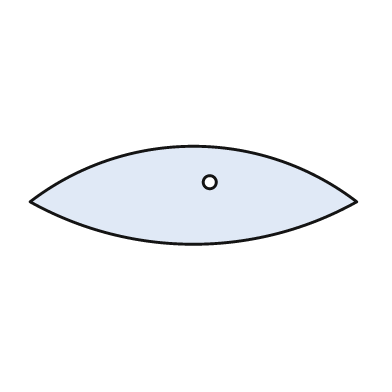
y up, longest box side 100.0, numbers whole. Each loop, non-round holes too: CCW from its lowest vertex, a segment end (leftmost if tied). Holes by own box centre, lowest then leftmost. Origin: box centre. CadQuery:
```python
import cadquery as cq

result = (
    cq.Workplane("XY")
    .moveTo(-50.0, -2.0)
    .threePointArc((0.0, -15.0), (50.0, -2.0))
    .threePointArc((0.0, 15.0), (-50.0, -2.0))
    .close()
    .moveTo(5.0, 4.0)
    .circle(2.0)
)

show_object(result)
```